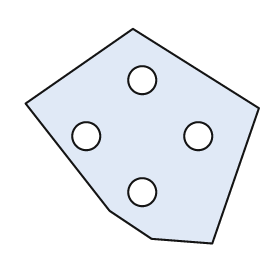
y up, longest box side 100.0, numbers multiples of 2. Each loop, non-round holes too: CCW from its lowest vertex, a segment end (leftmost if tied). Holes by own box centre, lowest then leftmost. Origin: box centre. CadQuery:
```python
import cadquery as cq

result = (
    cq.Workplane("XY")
    .moveTo(30.0, -46.0)
    .lineTo(50.0, 12.0)
    .lineTo(-4.0, 46.0)
    .lineTo(-50.0, 14.0)
    .lineTo(-14.0, -32.0)
    .lineTo(4.0, -44.0)
    .close()
    .moveTo(0.0, -24.0)
    .circle(6.0)
    .moveTo(-24.0, 0.0)
    .circle(6.0)
    .moveTo(24.0, 0.0)
    .circle(6.0)
    .moveTo(0.0, 24.0)
    .circle(6.0)
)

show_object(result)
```